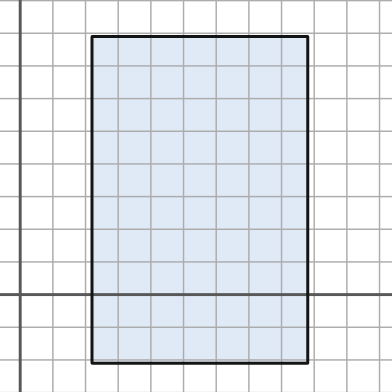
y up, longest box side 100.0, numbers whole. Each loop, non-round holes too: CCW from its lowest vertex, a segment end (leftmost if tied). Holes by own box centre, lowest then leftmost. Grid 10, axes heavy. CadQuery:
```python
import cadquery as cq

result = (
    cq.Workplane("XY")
    .moveTo(22.0, -21.0)
    .lineTo(88.0, -21.0)
    .lineTo(88.0, 79.0)
    .lineTo(22.0, 79.0)
    .close()
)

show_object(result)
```